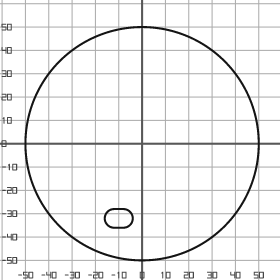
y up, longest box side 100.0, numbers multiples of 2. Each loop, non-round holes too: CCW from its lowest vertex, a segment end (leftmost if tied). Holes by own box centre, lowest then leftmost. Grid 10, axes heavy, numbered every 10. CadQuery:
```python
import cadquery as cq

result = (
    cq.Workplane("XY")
    .moveTo(0.0, 0.0)
    .circle(50.0)
    .moveTo(-12.0, -36.0)
    .lineTo(-8.0, -36.0)
    .threePointArc((-4.0, -32.0), (-8.0, -28.0))
    .lineTo(-12.0, -28.0)
    .threePointArc((-16.0, -32.0), (-12.0, -36.0))
    .close()
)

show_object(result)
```